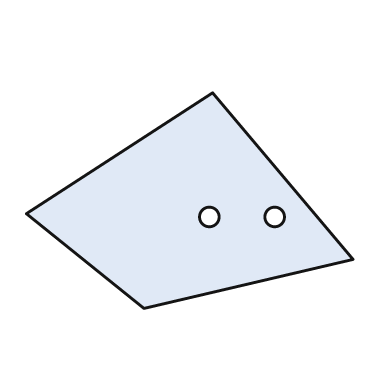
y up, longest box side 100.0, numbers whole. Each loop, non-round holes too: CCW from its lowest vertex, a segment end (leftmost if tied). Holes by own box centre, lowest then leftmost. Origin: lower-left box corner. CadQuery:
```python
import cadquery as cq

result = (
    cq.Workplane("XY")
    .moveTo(36.0, 0.0)
    .lineTo(100.0, 15.0)
    .lineTo(57.0, 66.0)
    .lineTo(0.0, 29.0)
    .close()
    .moveTo(56.0, 28.0)
    .circle(3.0)
    .moveTo(76.0, 28.0)
    .circle(3.0)
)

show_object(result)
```